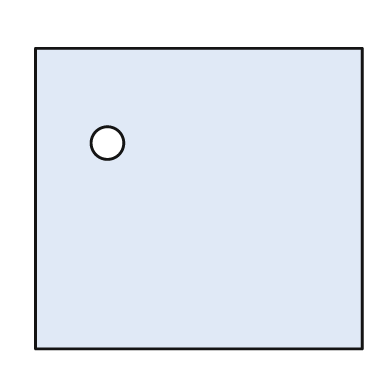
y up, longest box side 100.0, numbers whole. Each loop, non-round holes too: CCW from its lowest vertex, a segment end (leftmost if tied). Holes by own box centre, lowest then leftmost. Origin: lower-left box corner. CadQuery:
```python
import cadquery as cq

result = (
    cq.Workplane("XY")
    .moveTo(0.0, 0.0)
    .lineTo(100.0, 0.0)
    .lineTo(100.0, 92.0)
    .lineTo(0.0, 92.0)
    .close()
    .moveTo(22.0, 63.0)
    .circle(5.0)
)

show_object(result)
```